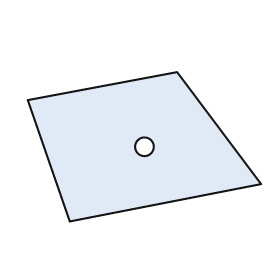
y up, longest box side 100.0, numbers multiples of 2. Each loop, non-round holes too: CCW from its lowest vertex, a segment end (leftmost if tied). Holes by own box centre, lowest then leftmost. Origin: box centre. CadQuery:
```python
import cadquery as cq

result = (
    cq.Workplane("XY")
    .moveTo(-32.0, -32.0)
    .lineTo(50.0, -16.0)
    .lineTo(14.0, 32.0)
    .lineTo(-50.0, 20.0)
    .close()
    .moveTo(0.0, 0.0)
    .circle(4.0)
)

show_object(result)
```